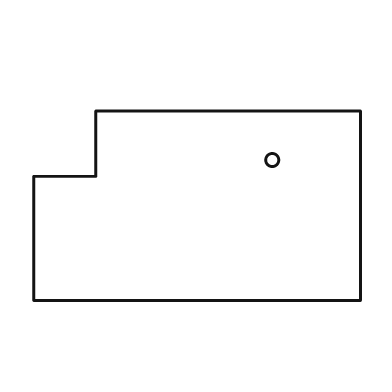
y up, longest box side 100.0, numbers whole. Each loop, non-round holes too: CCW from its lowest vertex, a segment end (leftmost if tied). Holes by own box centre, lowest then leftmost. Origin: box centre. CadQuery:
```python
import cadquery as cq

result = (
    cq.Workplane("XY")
    .moveTo(-50.0, -29.0)
    .lineTo(50.0, -29.0)
    .lineTo(50.0, 29.0)
    .lineTo(-31.0, 29.0)
    .lineTo(-31.0, 9.0)
    .lineTo(-50.0, 9.0)
    .close()
    .moveTo(23.0, 14.0)
    .circle(2.0)
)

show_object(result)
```